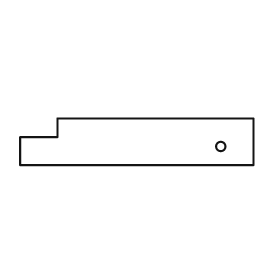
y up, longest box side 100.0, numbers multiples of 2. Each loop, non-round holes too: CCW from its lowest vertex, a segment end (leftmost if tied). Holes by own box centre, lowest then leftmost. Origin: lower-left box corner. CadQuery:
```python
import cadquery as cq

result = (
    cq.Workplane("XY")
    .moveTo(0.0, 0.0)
    .lineTo(100.0, 0.0)
    .lineTo(100.0, 20.0)
    .lineTo(16.0, 20.0)
    .lineTo(16.0, 12.0)
    .lineTo(0.0, 12.0)
    .close()
    .moveTo(86.0, 8.0)
    .circle(2.0)
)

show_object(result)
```